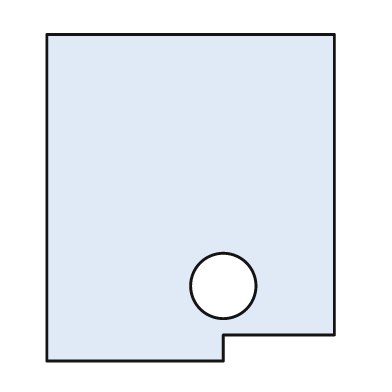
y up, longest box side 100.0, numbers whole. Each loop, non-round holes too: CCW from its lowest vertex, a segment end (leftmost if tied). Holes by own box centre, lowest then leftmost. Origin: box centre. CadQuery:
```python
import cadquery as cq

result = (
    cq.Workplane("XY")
    .moveTo(-44.0, -50.0)
    .lineTo(10.0, -50.0)
    .lineTo(10.0, -42.0)
    .lineTo(44.0, -42.0)
    .lineTo(44.0, 50.0)
    .lineTo(-44.0, 50.0)
    .close()
    .moveTo(10.0, -27.0)
    .circle(10.0)
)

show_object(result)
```